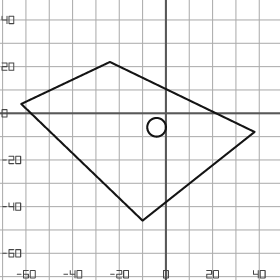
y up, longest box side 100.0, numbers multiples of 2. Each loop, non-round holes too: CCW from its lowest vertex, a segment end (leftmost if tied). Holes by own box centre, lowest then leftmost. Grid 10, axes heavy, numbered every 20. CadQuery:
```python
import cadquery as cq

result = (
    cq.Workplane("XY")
    .moveTo(-10.0, -46.0)
    .lineTo(38.0, -8.0)
    .lineTo(-24.0, 22.0)
    .lineTo(-62.0, 4.0)
    .close()
    .moveTo(-4.0, -6.0)
    .circle(4.0)
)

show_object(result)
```